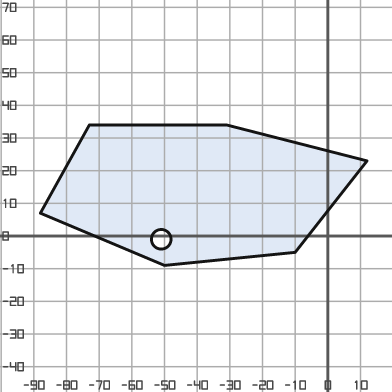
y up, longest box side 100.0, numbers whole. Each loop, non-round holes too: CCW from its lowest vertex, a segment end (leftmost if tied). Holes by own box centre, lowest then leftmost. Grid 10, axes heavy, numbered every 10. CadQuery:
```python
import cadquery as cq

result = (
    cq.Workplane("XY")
    .moveTo(-50.0, -9.0)
    .lineTo(-10.0, -5.0)
    .lineTo(12.0, 23.0)
    .lineTo(-31.0, 34.0)
    .lineTo(-73.0, 34.0)
    .lineTo(-88.0, 7.0)
    .close()
    .moveTo(-51.0, -1.0)
    .circle(3.0)
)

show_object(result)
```